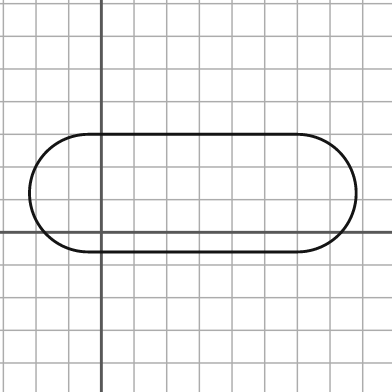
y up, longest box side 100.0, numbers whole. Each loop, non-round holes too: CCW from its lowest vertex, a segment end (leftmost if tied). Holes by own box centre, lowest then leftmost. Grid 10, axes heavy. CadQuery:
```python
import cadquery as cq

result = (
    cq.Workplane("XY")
    .moveTo(-4.0, -6.0)
    .lineTo(60.0, -6.0)
    .threePointArc((78.0, 12.0), (60.0, 30.0))
    .lineTo(-4.0, 30.0)
    .threePointArc((-22.0, 12.0), (-4.0, -6.0))
    .close()
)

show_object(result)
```